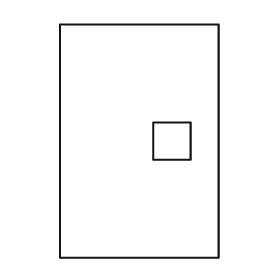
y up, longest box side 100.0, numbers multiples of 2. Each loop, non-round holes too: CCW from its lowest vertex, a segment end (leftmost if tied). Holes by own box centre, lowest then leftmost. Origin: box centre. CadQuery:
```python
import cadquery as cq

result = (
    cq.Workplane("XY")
    .moveTo(-34.0, -50.0)
    .lineTo(34.0, -50.0)
    .lineTo(34.0, 50.0)
    .lineTo(-34.0, 50.0)
    .close()
    .moveTo(6.0, -8.0)
    .lineTo(22.0, -8.0)
    .lineTo(22.0, 8.0)
    .lineTo(6.0, 8.0)
    .close()
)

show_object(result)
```